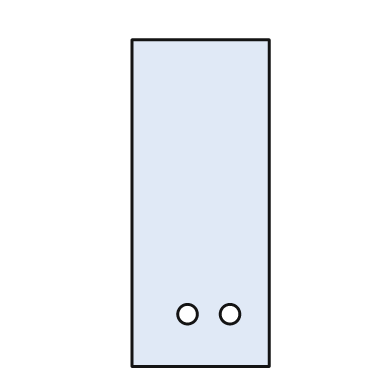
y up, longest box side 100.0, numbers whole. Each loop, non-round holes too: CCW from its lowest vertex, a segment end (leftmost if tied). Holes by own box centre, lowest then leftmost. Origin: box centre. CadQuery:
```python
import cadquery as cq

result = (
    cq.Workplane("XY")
    .moveTo(-21.0, -50.0)
    .lineTo(21.0, -50.0)
    .lineTo(21.0, 50.0)
    .lineTo(-21.0, 50.0)
    .close()
    .moveTo(-4.0, -34.0)
    .circle(3.0)
    .moveTo(9.0, -34.0)
    .circle(3.0)
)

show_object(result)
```